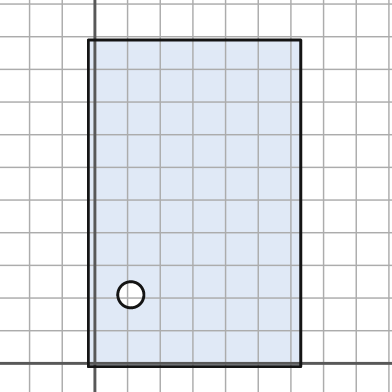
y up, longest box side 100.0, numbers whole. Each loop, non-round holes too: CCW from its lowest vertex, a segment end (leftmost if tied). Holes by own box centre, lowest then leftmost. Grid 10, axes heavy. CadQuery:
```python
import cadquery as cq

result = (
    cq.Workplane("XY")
    .moveTo(-2.0, -1.0)
    .lineTo(63.0, -1.0)
    .lineTo(63.0, 99.0)
    .lineTo(-2.0, 99.0)
    .close()
    .moveTo(11.0, 21.0)
    .circle(4.0)
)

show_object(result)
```